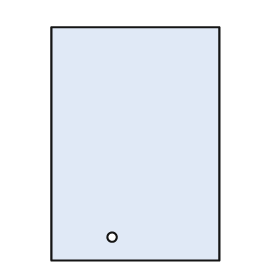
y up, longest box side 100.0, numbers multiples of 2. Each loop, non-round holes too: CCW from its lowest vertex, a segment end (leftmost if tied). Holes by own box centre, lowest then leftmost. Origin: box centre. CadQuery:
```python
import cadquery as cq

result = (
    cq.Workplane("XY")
    .moveTo(-36.0, -50.0)
    .lineTo(36.0, -50.0)
    .lineTo(36.0, 50.0)
    .lineTo(-36.0, 50.0)
    .close()
    .moveTo(-10.0, -40.0)
    .circle(2.0)
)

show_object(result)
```